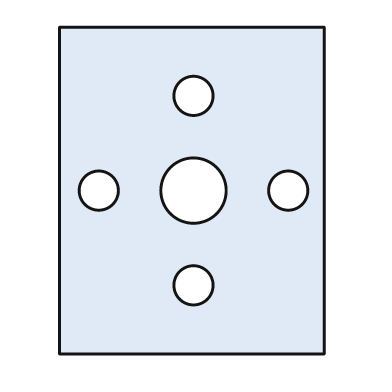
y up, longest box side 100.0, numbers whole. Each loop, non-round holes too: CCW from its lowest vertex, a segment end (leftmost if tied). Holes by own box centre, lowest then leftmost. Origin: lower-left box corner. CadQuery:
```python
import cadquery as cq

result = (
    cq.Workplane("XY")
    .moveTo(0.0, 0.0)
    .lineTo(81.0, 0.0)
    .lineTo(81.0, 100.0)
    .lineTo(0.0, 100.0)
    .close()
    .moveTo(41.0, 21.0)
    .circle(6.0)
    .moveTo(12.0, 50.0)
    .circle(6.0)
    .moveTo(41.0, 50.0)
    .circle(10.0)
    .moveTo(70.0, 50.0)
    .circle(6.0)
    .moveTo(41.0, 79.0)
    .circle(6.0)
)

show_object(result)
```